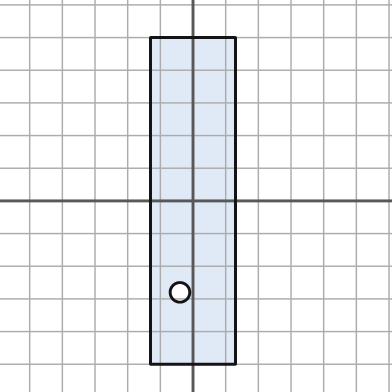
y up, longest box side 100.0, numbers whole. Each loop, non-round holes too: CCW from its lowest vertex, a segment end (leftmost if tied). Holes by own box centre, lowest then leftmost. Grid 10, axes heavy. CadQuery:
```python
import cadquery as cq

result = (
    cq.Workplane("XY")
    .moveTo(-13.0, -50.0)
    .lineTo(13.0, -50.0)
    .lineTo(13.0, 50.0)
    .lineTo(-13.0, 50.0)
    .close()
    .moveTo(-4.0, -28.0)
    .circle(3.0)
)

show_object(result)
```